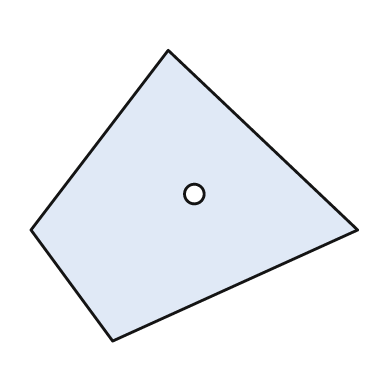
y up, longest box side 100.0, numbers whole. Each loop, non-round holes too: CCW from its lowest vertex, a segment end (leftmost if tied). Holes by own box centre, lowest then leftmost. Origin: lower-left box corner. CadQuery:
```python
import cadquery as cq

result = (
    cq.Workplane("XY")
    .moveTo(25.0, 0.0)
    .lineTo(100.0, 34.0)
    .lineTo(42.0, 89.0)
    .lineTo(0.0, 34.0)
    .close()
    .moveTo(50.0, 45.0)
    .circle(3.0)
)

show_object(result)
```